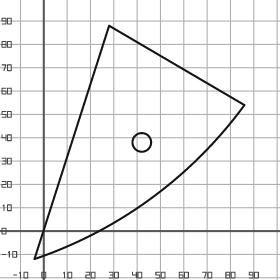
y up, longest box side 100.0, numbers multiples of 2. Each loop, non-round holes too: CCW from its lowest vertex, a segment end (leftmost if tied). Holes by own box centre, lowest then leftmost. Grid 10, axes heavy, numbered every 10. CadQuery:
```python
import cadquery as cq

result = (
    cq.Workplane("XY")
    .moveTo(-4.0, -12.0)
    .threePointArc((46.0, 14.0), (86.0, 54.0))
    .lineTo(28.0, 88.0)
    .close()
    .moveTo(42.0, 38.0)
    .circle(4.0)
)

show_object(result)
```